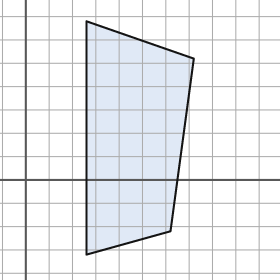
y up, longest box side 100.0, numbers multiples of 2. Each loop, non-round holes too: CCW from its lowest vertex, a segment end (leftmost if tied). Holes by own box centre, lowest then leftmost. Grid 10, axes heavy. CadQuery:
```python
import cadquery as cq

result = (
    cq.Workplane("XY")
    .moveTo(26.0, -32.0)
    .lineTo(62.0, -22.0)
    .lineTo(72.0, 52.0)
    .lineTo(26.0, 68.0)
    .close()
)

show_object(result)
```